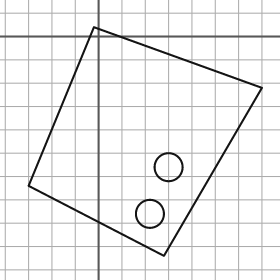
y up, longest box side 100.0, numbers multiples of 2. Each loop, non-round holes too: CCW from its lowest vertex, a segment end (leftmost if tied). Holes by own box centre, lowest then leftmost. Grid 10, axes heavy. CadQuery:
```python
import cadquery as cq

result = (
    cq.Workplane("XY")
    .moveTo(28.0, -94.0)
    .lineTo(70.0, -22.0)
    .lineTo(-2.0, 4.0)
    .lineTo(-30.0, -64.0)
    .close()
    .moveTo(22.0, -76.0)
    .circle(6.0)
    .moveTo(30.0, -56.0)
    .circle(6.0)
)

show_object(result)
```